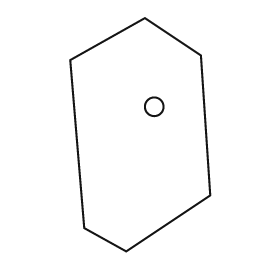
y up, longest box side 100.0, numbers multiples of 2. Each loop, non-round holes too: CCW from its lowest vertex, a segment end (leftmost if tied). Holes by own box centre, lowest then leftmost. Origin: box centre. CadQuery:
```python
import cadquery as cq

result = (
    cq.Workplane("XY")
    .moveTo(-6.0, -50.0)
    .lineTo(30.0, -26.0)
    .lineTo(26.0, 34.0)
    .lineTo(2.0, 50.0)
    .lineTo(-30.0, 32.0)
    .lineTo(-24.0, -40.0)
    .close()
    .moveTo(6.0, 12.0)
    .circle(4.0)
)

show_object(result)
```